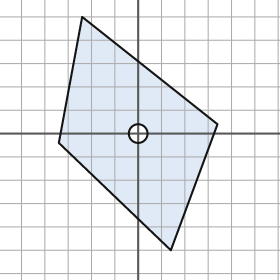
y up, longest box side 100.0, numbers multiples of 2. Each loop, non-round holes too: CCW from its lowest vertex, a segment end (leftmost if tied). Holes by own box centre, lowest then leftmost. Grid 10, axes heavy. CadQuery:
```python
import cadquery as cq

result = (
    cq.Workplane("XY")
    .moveTo(14.0, -50.0)
    .lineTo(34.0, 4.0)
    .lineTo(-24.0, 50.0)
    .lineTo(-34.0, -4.0)
    .close()
    .moveTo(0.0, 0.0)
    .circle(4.0)
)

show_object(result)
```